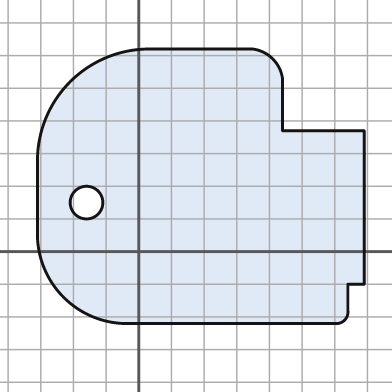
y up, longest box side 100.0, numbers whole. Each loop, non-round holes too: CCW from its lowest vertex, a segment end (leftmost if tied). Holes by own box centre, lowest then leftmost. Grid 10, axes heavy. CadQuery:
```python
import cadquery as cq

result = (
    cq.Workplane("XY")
    .moveTo(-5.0, -22.0)
    .lineTo(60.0, -22.0)
    .threePointArc((63.0, -21.0), (64.0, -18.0))
    .lineTo(64.0, -10.0)
    .lineTo(69.0, -10.0)
    .lineTo(69.0, 37.0)
    .lineTo(44.0, 37.0)
    .lineTo(44.0, 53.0)
    .threePointArc((41.0, 59.0), (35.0, 62.0))
    .lineTo(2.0, 62.0)
    .threePointArc((-21.0, 52.0), (-31.0, 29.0))
    .lineTo(-31.0, 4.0)
    .threePointArc((-23.0, -14.0), (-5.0, -22.0))
    .close()
    .moveTo(-16.0, 15.0)
    .circle(5.0)
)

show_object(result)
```